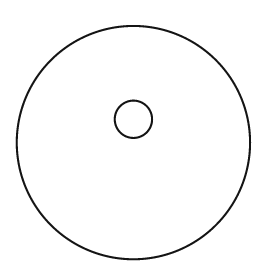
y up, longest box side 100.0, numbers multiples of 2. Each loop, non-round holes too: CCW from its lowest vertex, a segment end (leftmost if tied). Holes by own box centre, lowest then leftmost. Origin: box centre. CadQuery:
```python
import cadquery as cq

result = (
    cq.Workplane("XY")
    .moveTo(0.0, 0.0)
    .circle(50.0)
    .moveTo(0.0, 10.0)
    .circle(8.0)
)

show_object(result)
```